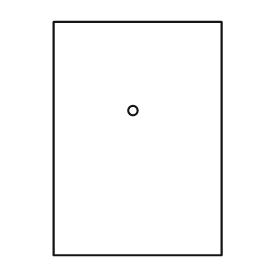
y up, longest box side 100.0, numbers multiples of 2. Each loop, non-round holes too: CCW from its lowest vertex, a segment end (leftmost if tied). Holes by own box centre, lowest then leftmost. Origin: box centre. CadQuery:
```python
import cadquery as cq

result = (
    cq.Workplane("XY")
    .moveTo(-36.0, -50.0)
    .lineTo(36.0, -50.0)
    .lineTo(36.0, 50.0)
    .lineTo(-36.0, 50.0)
    .close()
    .moveTo(-2.0, 12.0)
    .circle(2.0)
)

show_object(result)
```